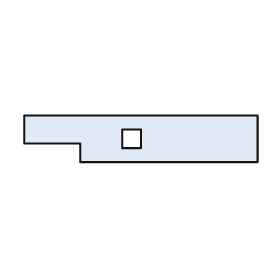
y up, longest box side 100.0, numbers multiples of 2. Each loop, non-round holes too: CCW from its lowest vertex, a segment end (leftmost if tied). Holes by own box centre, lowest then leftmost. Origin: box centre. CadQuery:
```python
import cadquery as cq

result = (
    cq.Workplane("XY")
    .moveTo(-26.0, -10.0)
    .lineTo(50.0, -10.0)
    .lineTo(50.0, 10.0)
    .lineTo(-50.0, 10.0)
    .lineTo(-50.0, -2.0)
    .lineTo(-26.0, -2.0)
    .close()
    .moveTo(-8.0, -4.0)
    .lineTo(0.0, -4.0)
    .lineTo(0.0, 4.0)
    .lineTo(-8.0, 4.0)
    .close()
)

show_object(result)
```